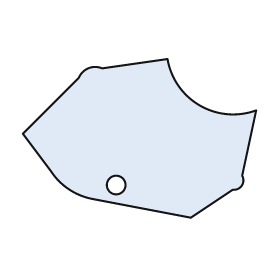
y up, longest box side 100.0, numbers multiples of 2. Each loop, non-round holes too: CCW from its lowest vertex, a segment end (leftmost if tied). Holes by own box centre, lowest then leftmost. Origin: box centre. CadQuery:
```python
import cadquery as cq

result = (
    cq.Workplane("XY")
    .moveTo(22.0, -34.0)
    .lineTo(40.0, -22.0)
    .threePointArc((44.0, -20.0), (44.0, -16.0))
    .lineTo(50.0, 12.0)
    .threePointArc((26.0, 14.0), (12.0, 34.0))
    .lineTo(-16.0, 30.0)
    .threePointArc((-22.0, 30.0), (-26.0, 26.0))
    .lineTo(-50.0, 2.0)
    .lineTo(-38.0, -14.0)
    .threePointArc((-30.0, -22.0), (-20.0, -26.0))
    .close()
    .moveTo(-10.0, -20.0)
    .circle(4.0)
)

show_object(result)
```